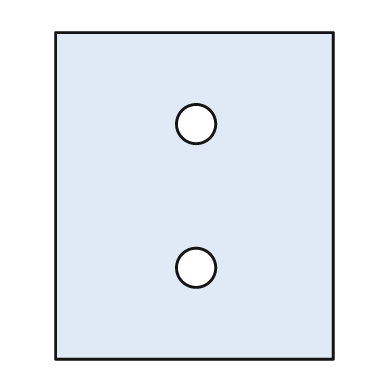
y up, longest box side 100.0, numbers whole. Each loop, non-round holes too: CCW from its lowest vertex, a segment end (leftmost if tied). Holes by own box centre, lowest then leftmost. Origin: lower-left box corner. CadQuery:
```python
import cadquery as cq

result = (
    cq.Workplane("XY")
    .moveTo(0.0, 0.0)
    .lineTo(85.0, 0.0)
    .lineTo(85.0, 100.0)
    .lineTo(0.0, 100.0)
    .close()
    .moveTo(43.0, 28.0)
    .circle(6.0)
    .moveTo(43.0, 72.0)
    .circle(6.0)
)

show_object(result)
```